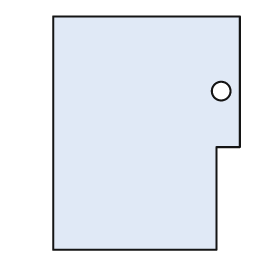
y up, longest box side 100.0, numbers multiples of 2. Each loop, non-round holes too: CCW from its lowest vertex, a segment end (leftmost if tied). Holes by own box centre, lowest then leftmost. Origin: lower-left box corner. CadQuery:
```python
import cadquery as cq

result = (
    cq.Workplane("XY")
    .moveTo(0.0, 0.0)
    .lineTo(70.0, 0.0)
    .lineTo(70.0, 44.0)
    .lineTo(80.0, 44.0)
    .lineTo(80.0, 100.0)
    .lineTo(0.0, 100.0)
    .close()
    .moveTo(72.0, 68.0)
    .circle(4.0)
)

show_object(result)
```